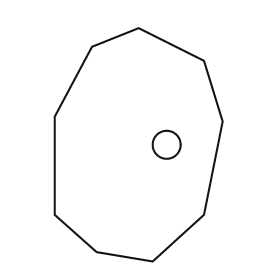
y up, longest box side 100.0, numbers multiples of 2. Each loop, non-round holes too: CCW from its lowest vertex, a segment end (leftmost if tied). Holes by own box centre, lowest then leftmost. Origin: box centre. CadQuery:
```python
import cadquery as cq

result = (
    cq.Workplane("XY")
    .moveTo(6.0, -50.0)
    .lineTo(28.0, -30.0)
    .lineTo(36.0, 10.0)
    .lineTo(28.0, 36.0)
    .lineTo(0.0, 50.0)
    .lineTo(-20.0, 42.0)
    .lineTo(-36.0, 12.0)
    .lineTo(-36.0, -30.0)
    .lineTo(-18.0, -46.0)
    .close()
    .moveTo(12.0, 0.0)
    .circle(6.0)
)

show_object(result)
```